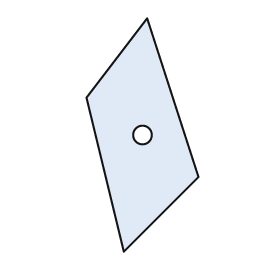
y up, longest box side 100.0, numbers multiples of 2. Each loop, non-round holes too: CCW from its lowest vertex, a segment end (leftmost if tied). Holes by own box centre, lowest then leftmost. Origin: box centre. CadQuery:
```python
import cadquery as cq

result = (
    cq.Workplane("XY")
    .moveTo(-8.0, -50.0)
    .lineTo(24.0, -18.0)
    .lineTo(2.0, 50.0)
    .lineTo(-24.0, 16.0)
    .close()
    .moveTo(0.0, 0.0)
    .circle(4.0)
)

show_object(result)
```